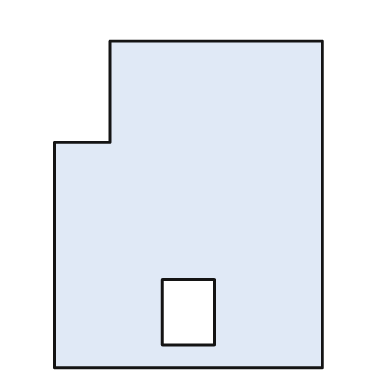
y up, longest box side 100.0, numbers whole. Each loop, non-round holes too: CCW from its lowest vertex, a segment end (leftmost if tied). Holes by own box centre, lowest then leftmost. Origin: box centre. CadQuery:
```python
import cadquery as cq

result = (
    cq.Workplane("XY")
    .moveTo(-41.0, -50.0)
    .lineTo(41.0, -50.0)
    .lineTo(41.0, 50.0)
    .lineTo(-24.0, 50.0)
    .lineTo(-24.0, 19.0)
    .lineTo(-41.0, 19.0)
    .close()
    .moveTo(-8.0, -43.0)
    .lineTo(8.0, -43.0)
    .lineTo(8.0, -23.0)
    .lineTo(-8.0, -23.0)
    .close()
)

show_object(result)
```